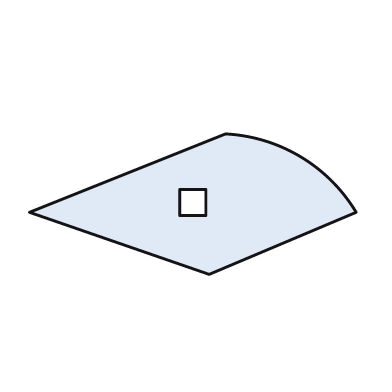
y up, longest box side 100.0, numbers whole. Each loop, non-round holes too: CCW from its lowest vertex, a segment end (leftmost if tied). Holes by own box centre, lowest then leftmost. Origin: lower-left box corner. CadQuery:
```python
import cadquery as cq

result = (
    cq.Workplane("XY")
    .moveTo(55.0, 0.0)
    .lineTo(100.0, 19.0)
    .threePointArc((83.0, 36.0), (60.0, 43.0))
    .lineTo(0.0, 19.0)
    .close()
    .moveTo(46.0, 18.0)
    .lineTo(54.0, 18.0)
    .lineTo(54.0, 26.0)
    .lineTo(46.0, 26.0)
    .close()
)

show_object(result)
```